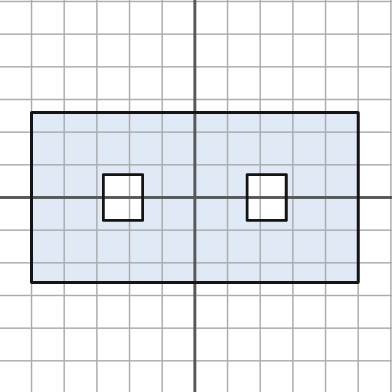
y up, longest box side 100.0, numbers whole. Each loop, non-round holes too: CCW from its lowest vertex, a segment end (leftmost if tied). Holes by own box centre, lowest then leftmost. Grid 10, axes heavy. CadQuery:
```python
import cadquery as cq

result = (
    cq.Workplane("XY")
    .moveTo(-50.0, -26.0)
    .lineTo(50.0, -26.0)
    .lineTo(50.0, 26.0)
    .lineTo(-50.0, 26.0)
    .close()
    .moveTo(-28.0, -7.0)
    .lineTo(-16.0, -7.0)
    .lineTo(-16.0, 7.0)
    .lineTo(-28.0, 7.0)
    .close()
    .moveTo(16.0, -7.0)
    .lineTo(28.0, -7.0)
    .lineTo(28.0, 7.0)
    .lineTo(16.0, 7.0)
    .close()
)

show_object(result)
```